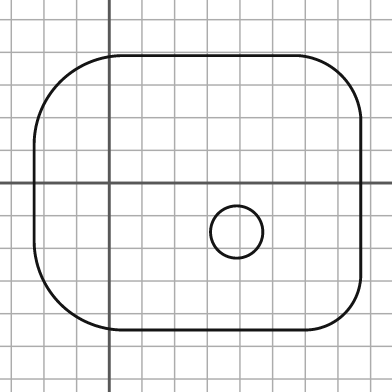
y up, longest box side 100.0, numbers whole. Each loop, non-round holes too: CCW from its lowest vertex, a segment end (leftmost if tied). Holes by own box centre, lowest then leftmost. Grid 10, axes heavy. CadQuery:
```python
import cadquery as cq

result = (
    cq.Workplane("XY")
    .moveTo(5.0, -45.0)
    .lineTo(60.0, -45.0)
    .threePointArc((72.0, -40.0), (77.0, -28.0))
    .lineTo(77.0, 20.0)
    .threePointArc((71.0, 33.0), (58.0, 39.0))
    .lineTo(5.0, 39.0)
    .threePointArc((-15.0, 31.0), (-23.0, 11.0))
    .lineTo(-23.0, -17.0)
    .threePointArc((-15.0, -37.0), (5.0, -45.0))
    .close()
    .moveTo(39.0, -15.0)
    .circle(8.0)
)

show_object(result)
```